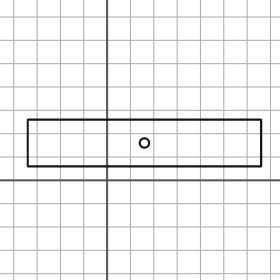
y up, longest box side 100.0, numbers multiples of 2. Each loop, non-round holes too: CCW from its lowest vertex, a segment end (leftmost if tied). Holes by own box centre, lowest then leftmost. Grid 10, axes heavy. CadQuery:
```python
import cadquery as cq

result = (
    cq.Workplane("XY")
    .moveTo(-34.0, 6.0)
    .lineTo(66.0, 6.0)
    .lineTo(66.0, 26.0)
    .lineTo(-34.0, 26.0)
    .close()
    .moveTo(16.0, 16.0)
    .circle(2.0)
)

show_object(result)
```